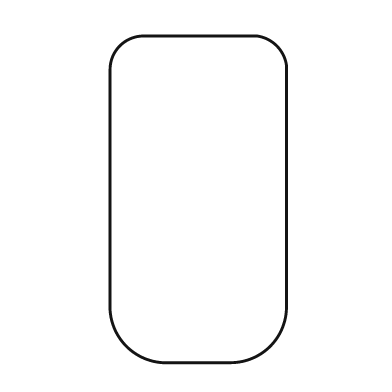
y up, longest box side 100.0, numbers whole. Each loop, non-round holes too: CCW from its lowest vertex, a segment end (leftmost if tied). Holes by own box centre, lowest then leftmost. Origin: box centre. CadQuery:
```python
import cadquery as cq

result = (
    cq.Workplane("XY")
    .moveTo(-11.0, -50.0)
    .lineTo(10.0, -50.0)
    .threePointArc((22.0, -45.0), (27.0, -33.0))
    .lineTo(27.0, 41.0)
    .threePointArc((24.0, 47.0), (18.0, 50.0))
    .lineTo(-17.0, 50.0)
    .threePointArc((-24.0, 47.0), (-27.0, 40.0))
    .lineTo(-27.0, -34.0)
    .threePointArc((-22.0, -45.0), (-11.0, -50.0))
    .close()
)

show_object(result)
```